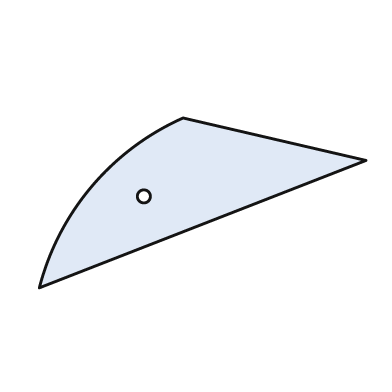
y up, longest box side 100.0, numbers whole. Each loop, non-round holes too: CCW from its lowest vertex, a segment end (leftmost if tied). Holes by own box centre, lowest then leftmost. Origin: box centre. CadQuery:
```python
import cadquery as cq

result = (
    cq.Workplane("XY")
    .moveTo(-50.0, -26.0)
    .lineTo(50.0, 13.0)
    .lineTo(-6.0, 26.0)
    .threePointArc((-34.0, 5.0), (-50.0, -26.0))
    .close()
    .moveTo(-18.0, 2.0)
    .circle(2.0)
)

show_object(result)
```